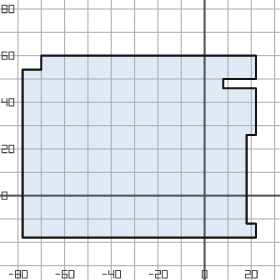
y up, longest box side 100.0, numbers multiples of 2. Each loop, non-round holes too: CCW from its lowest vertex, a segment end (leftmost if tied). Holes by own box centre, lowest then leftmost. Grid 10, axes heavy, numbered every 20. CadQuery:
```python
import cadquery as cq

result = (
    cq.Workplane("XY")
    .moveTo(-78.0, -18.0)
    .lineTo(22.0, -18.0)
    .lineTo(22.0, -12.0)
    .lineTo(18.0, -12.0)
    .lineTo(18.0, 26.0)
    .lineTo(22.0, 26.0)
    .lineTo(22.0, 46.0)
    .lineTo(8.0, 46.0)
    .lineTo(8.0, 50.0)
    .lineTo(22.0, 50.0)
    .lineTo(22.0, 60.0)
    .lineTo(-70.0, 60.0)
    .lineTo(-70.0, 54.0)
    .lineTo(-78.0, 54.0)
    .close()
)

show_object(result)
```